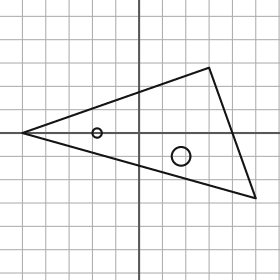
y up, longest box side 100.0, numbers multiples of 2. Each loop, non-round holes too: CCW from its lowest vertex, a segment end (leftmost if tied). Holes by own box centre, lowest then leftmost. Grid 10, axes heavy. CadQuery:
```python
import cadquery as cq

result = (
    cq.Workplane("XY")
    .moveTo(50.0, -28.0)
    .lineTo(30.0, 28.0)
    .lineTo(-50.0, 0.0)
    .close()
    .moveTo(18.0, -10.0)
    .circle(4.0)
    .moveTo(-18.0, 0.0)
    .circle(2.0)
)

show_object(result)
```